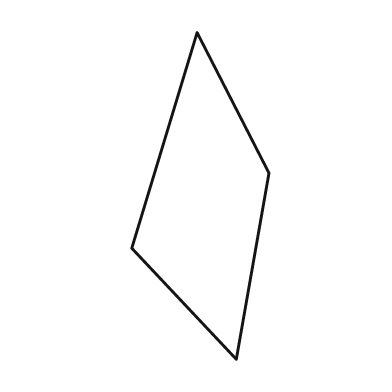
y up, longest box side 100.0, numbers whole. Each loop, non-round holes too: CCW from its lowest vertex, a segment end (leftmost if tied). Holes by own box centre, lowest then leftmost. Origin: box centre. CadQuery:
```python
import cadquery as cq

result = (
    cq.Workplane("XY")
    .moveTo(11.0, -50.0)
    .lineTo(21.0, 7.0)
    .lineTo(-1.0, 50.0)
    .lineTo(-21.0, -16.0)
    .close()
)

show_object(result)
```